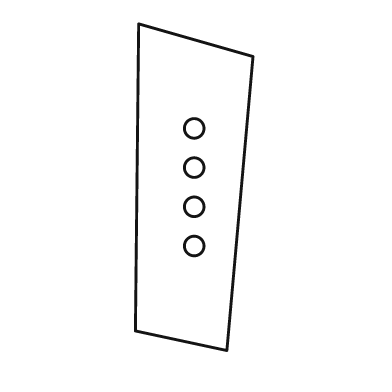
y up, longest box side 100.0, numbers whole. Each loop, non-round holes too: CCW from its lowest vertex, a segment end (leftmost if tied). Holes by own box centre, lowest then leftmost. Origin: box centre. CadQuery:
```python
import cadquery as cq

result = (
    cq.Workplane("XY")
    .moveTo(10.0, -50.0)
    .lineTo(18.0, 40.0)
    .lineTo(-17.0, 50.0)
    .lineTo(-18.0, -44.0)
    .close()
    .moveTo(0.0, -18.0)
    .circle(3.0)
    .moveTo(0.0, -6.0)
    .circle(3.0)
    .moveTo(0.0, 6.0)
    .circle(3.0)
    .moveTo(0.0, 18.0)
    .circle(3.0)
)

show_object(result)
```